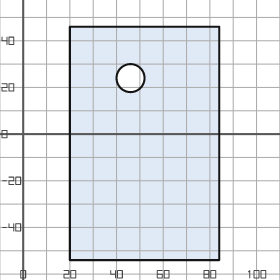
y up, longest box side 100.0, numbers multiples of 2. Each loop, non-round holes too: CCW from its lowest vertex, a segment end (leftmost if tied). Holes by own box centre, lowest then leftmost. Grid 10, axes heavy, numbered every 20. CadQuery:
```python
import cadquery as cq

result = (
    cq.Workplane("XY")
    .moveTo(20.0, -54.0)
    .lineTo(84.0, -54.0)
    .lineTo(84.0, 46.0)
    .lineTo(20.0, 46.0)
    .close()
    .moveTo(46.0, 24.0)
    .circle(6.0)
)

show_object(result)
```